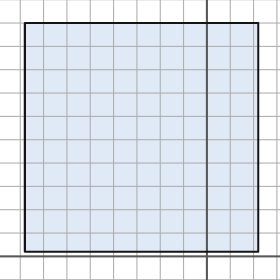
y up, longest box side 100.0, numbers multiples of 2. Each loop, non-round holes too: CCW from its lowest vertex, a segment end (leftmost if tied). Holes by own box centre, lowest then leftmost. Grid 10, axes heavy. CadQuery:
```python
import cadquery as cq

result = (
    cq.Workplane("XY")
    .moveTo(-78.0, 2.0)
    .lineTo(22.0, 2.0)
    .lineTo(22.0, 100.0)
    .lineTo(-78.0, 100.0)
    .close()
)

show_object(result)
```